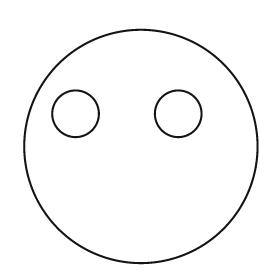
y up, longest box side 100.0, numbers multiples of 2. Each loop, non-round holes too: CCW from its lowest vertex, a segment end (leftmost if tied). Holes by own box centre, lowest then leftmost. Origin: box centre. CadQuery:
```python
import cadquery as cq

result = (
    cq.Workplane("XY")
    .moveTo(0.0, 0.0)
    .circle(50.0)
    .moveTo(-28.0, 14.0)
    .circle(10.0)
    .moveTo(16.0, 14.0)
    .circle(10.0)
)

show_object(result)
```